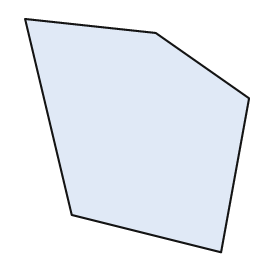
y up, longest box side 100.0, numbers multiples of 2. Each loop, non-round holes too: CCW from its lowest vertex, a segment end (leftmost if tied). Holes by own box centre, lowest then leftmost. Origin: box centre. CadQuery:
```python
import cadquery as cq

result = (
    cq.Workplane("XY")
    .moveTo(36.0, -50.0)
    .lineTo(48.0, 16.0)
    .lineTo(8.0, 44.0)
    .lineTo(-48.0, 50.0)
    .lineTo(-28.0, -34.0)
    .close()
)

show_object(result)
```